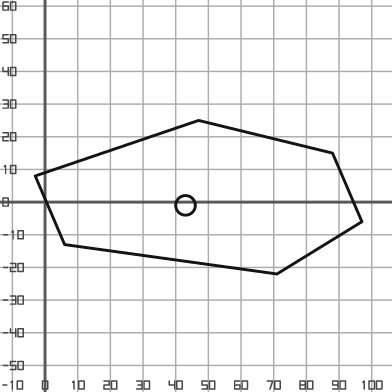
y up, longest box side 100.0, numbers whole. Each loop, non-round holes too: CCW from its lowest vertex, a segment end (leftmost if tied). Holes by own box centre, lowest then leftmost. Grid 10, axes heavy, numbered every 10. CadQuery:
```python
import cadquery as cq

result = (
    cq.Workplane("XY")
    .moveTo(71.0, -22.0)
    .lineTo(97.0, -6.0)
    .lineTo(88.0, 15.0)
    .lineTo(47.0, 25.0)
    .lineTo(-3.0, 8.0)
    .lineTo(6.0, -13.0)
    .close()
    .moveTo(43.0, -1.0)
    .circle(3.0)
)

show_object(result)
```